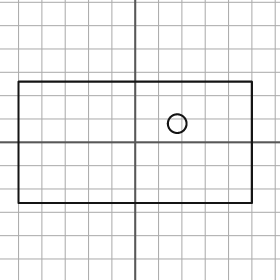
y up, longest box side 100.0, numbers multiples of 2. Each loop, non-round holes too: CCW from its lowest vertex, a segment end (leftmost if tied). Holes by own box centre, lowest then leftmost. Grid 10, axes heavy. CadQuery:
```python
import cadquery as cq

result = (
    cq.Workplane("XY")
    .moveTo(-50.0, -26.0)
    .lineTo(50.0, -26.0)
    .lineTo(50.0, 26.0)
    .lineTo(-50.0, 26.0)
    .close()
    .moveTo(18.0, 8.0)
    .circle(4.0)
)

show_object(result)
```